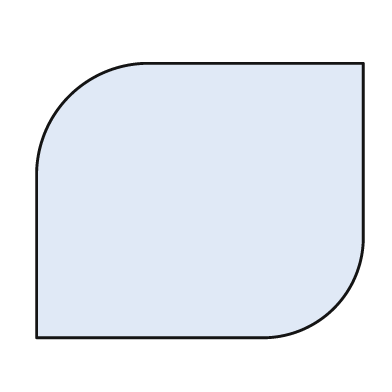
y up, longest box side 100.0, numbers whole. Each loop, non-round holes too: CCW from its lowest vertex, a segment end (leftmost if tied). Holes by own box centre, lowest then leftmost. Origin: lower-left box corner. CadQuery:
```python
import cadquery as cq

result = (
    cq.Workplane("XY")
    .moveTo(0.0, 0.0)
    .lineTo(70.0, 0.0)
    .threePointArc((91.0, 9.0), (100.0, 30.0))
    .lineTo(100.0, 84.0)
    .lineTo(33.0, 84.0)
    .threePointArc((10.0, 74.0), (0.0, 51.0))
    .close()
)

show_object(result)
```